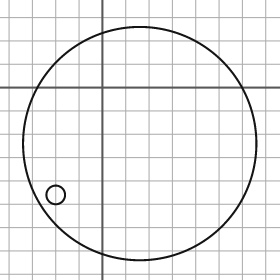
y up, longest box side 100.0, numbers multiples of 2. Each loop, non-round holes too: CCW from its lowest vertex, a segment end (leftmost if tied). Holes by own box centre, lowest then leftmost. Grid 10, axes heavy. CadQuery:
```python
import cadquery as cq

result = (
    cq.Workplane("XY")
    .moveTo(16.0, -24.0)
    .circle(50.0)
    .moveTo(-20.0, -46.0)
    .circle(4.0)
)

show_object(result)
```